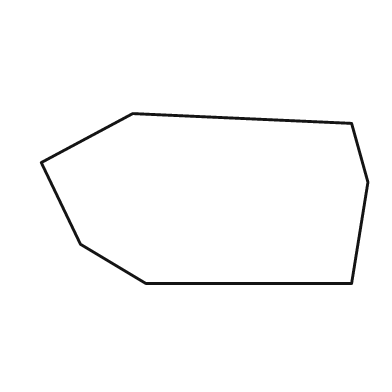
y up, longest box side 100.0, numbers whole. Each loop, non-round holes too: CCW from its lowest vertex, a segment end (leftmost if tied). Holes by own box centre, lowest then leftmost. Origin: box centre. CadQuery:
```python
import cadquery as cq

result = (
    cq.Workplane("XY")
    .moveTo(-18.0, -26.0)
    .lineTo(45.0, -26.0)
    .lineTo(50.0, 5.0)
    .lineTo(45.0, 23.0)
    .lineTo(-22.0, 26.0)
    .lineTo(-50.0, 11.0)
    .lineTo(-38.0, -14.0)
    .close()
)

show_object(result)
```